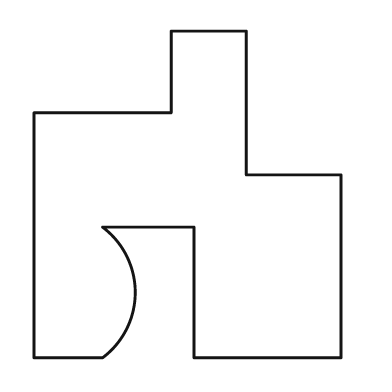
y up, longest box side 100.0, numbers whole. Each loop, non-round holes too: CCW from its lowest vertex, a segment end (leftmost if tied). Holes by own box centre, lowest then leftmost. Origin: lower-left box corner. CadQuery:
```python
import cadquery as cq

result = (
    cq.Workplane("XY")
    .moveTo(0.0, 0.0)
    .lineTo(21.0, 0.0)
    .threePointArc((31.0, 20.0), (21.0, 40.0))
    .lineTo(49.0, 40.0)
    .lineTo(49.0, 0.0)
    .lineTo(94.0, 0.0)
    .lineTo(94.0, 56.0)
    .lineTo(65.0, 56.0)
    .lineTo(65.0, 100.0)
    .lineTo(42.0, 100.0)
    .lineTo(42.0, 75.0)
    .lineTo(0.0, 75.0)
    .close()
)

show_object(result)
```